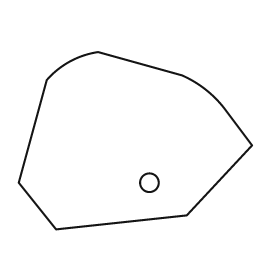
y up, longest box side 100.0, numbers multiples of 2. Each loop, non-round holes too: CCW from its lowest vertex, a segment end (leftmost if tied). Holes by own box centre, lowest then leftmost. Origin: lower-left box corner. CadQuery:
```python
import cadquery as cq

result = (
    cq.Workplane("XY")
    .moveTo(16.0, 0.0)
    .lineTo(72.0, 6.0)
    .lineTo(100.0, 36.0)
    .lineTo(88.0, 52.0)
    .threePointArc((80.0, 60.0), (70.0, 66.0))
    .lineTo(34.0, 76.0)
    .threePointArc((22.0, 72.0), (12.0, 64.0))
    .lineTo(0.0, 20.0)
    .close()
    .moveTo(56.0, 20.0)
    .circle(4.0)
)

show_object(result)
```